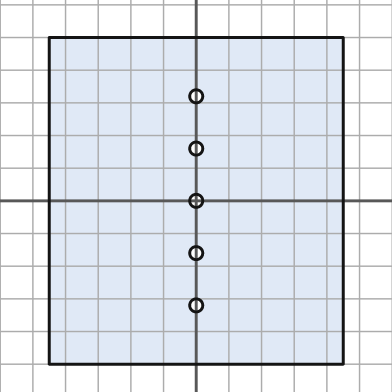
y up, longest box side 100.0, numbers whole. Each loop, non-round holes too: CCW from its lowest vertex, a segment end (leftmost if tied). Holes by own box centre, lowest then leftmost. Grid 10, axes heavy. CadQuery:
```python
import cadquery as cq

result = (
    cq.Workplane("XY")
    .moveTo(-45.0, -50.0)
    .lineTo(45.0, -50.0)
    .lineTo(45.0, 50.0)
    .lineTo(-45.0, 50.0)
    .close()
    .moveTo(0.0, -32.0)
    .circle(2.0)
    .moveTo(0.0, -16.0)
    .circle(2.0)
    .moveTo(0.0, 0.0)
    .circle(2.0)
    .moveTo(0.0, 16.0)
    .circle(2.0)
    .moveTo(0.0, 32.0)
    .circle(2.0)
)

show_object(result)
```